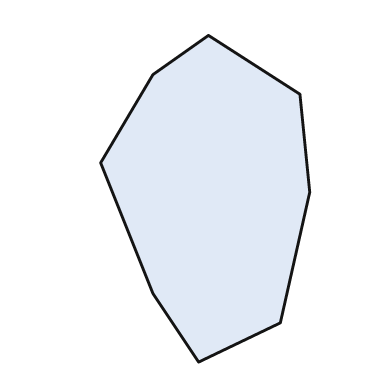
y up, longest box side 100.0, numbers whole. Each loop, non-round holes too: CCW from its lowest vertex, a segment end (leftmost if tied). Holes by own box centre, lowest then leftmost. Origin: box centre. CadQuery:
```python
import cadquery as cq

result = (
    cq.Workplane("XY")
    .moveTo(-2.0, -50.0)
    .lineTo(23.0, -38.0)
    .lineTo(32.0, 2.0)
    .lineTo(29.0, 32.0)
    .lineTo(1.0, 50.0)
    .lineTo(-16.0, 38.0)
    .lineTo(-32.0, 11.0)
    .lineTo(-16.0, -29.0)
    .close()
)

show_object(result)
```